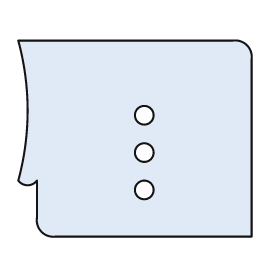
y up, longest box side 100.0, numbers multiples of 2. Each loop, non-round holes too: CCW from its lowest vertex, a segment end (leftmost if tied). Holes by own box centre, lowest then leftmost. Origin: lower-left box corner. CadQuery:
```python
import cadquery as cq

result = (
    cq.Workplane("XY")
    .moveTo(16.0, 0.0)
    .lineTo(100.0, 0.0)
    .lineTo(100.0, 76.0)
    .threePointArc((98.0, 82.0), (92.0, 84.0))
    .lineTo(0.0, 84.0)
    .threePointArc((4.0, 54.0), (0.0, 24.0))
    .threePointArc((4.0, 22.0), (8.0, 24.0))
    .lineTo(8.0, 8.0)
    .threePointArc((10.0, 2.0), (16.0, 0.0))
    .close()
    .moveTo(54.0, 20.0)
    .circle(4.0)
    .moveTo(54.0, 36.0)
    .circle(4.0)
    .moveTo(54.0, 52.0)
    .circle(4.0)
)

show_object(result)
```